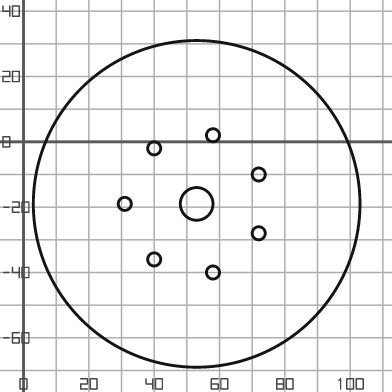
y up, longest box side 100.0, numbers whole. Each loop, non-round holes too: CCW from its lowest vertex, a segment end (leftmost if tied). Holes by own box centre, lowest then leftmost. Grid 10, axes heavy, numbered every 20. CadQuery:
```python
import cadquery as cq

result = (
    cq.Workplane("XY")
    .moveTo(53.0, -19.0)
    .circle(50.0)
    .moveTo(58.0, -40.0)
    .circle(2.0)
    .moveTo(40.0, -36.0)
    .circle(2.0)
    .moveTo(72.0, -28.0)
    .circle(2.0)
    .moveTo(31.0, -19.0)
    .circle(2.0)
    .moveTo(53.0, -19.0)
    .circle(5.0)
    .moveTo(72.0, -10.0)
    .circle(2.0)
    .moveTo(40.0, -2.0)
    .circle(2.0)
    .moveTo(58.0, 2.0)
    .circle(2.0)
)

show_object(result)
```